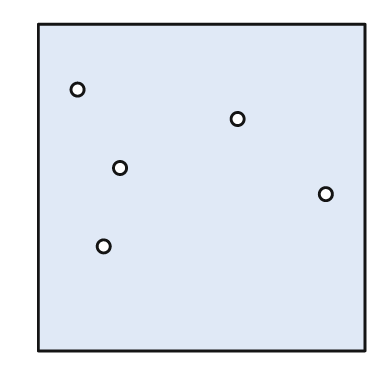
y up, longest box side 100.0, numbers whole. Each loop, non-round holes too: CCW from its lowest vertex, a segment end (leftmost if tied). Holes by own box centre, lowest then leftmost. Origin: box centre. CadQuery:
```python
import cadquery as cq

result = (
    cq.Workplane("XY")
    .moveTo(-50.0, -50.0)
    .lineTo(50.0, -50.0)
    .lineTo(50.0, 50.0)
    .lineTo(-50.0, 50.0)
    .close()
    .moveTo(-30.0, -18.0)
    .circle(2.0)
    .moveTo(38.0, -2.0)
    .circle(2.0)
    .moveTo(-25.0, 6.0)
    .circle(2.0)
    .moveTo(11.0, 21.0)
    .circle(2.0)
    .moveTo(-38.0, 30.0)
    .circle(2.0)
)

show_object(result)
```